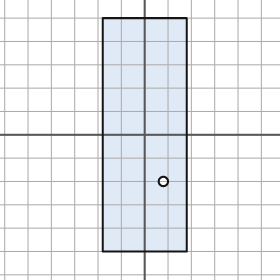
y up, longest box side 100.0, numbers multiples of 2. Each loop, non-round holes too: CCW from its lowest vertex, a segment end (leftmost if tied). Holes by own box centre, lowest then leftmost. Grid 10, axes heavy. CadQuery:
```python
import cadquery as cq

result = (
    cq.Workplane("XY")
    .moveTo(-18.0, -50.0)
    .lineTo(18.0, -50.0)
    .lineTo(18.0, 50.0)
    .lineTo(-18.0, 50.0)
    .close()
    .moveTo(8.0, -20.0)
    .circle(2.0)
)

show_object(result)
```